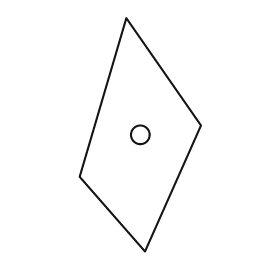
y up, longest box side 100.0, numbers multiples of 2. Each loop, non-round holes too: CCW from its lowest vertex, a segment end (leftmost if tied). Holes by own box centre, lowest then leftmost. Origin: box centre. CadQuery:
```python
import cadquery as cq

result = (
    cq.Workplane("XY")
    .moveTo(2.0, -50.0)
    .lineTo(26.0, 4.0)
    .lineTo(-6.0, 50.0)
    .lineTo(-26.0, -18.0)
    .close()
    .moveTo(0.0, 0.0)
    .circle(4.0)
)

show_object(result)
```